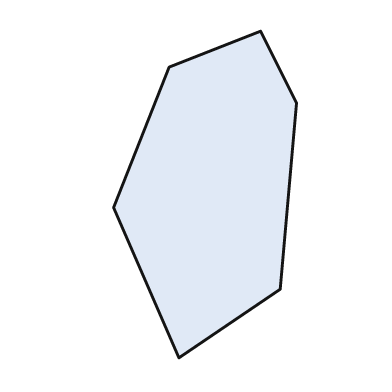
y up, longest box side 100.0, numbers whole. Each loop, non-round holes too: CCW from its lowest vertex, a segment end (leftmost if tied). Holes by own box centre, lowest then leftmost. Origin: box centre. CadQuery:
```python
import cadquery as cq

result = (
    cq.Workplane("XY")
    .moveTo(-8.0, -50.0)
    .lineTo(23.0, -29.0)
    .lineTo(28.0, 28.0)
    .lineTo(17.0, 50.0)
    .lineTo(-11.0, 39.0)
    .lineTo(-28.0, -4.0)
    .close()
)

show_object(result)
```